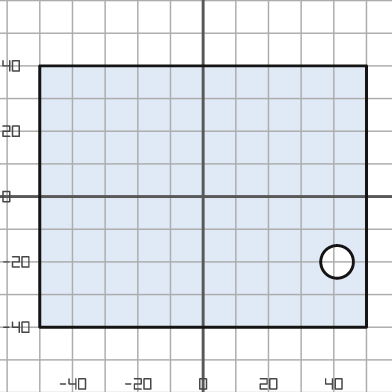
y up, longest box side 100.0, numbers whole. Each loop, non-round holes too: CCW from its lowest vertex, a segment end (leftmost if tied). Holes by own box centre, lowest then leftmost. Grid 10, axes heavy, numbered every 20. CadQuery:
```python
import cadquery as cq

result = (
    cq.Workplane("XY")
    .moveTo(-50.0, -40.0)
    .lineTo(50.0, -40.0)
    .lineTo(50.0, 40.0)
    .lineTo(-50.0, 40.0)
    .close()
    .moveTo(41.0, -20.0)
    .circle(5.0)
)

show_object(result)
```